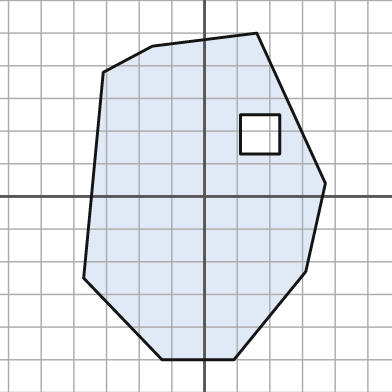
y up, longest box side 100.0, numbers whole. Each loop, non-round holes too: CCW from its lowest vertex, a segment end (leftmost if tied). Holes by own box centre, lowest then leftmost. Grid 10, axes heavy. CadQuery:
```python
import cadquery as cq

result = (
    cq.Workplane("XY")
    .moveTo(-13.0, -50.0)
    .lineTo(9.0, -50.0)
    .lineTo(31.0, -23.0)
    .lineTo(37.0, 4.0)
    .lineTo(16.0, 50.0)
    .lineTo(-16.0, 46.0)
    .lineTo(-31.0, 38.0)
    .lineTo(-37.0, -25.0)
    .close()
    .moveTo(11.0, 13.0)
    .lineTo(23.0, 13.0)
    .lineTo(23.0, 25.0)
    .lineTo(11.0, 25.0)
    .close()
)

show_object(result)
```